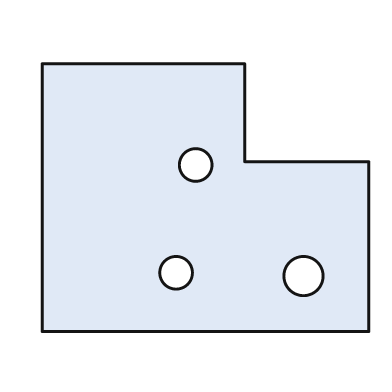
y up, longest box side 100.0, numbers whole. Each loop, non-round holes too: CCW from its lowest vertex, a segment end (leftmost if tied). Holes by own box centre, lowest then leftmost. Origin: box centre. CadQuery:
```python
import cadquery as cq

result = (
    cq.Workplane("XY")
    .moveTo(-50.0, -41.0)
    .lineTo(50.0, -41.0)
    .lineTo(50.0, 11.0)
    .lineTo(12.0, 11.0)
    .lineTo(12.0, 41.0)
    .lineTo(-50.0, 41.0)
    .close()
    .moveTo(30.0, -24.0)
    .circle(6.0)
    .moveTo(-9.0, -23.0)
    .circle(5.0)
    .moveTo(-3.0, 10.0)
    .circle(5.0)
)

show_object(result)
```